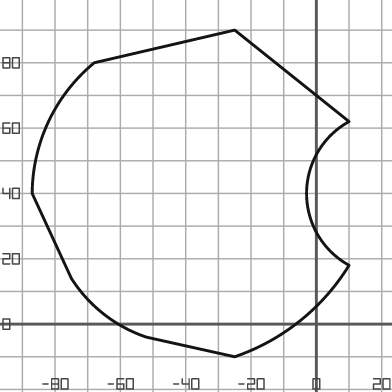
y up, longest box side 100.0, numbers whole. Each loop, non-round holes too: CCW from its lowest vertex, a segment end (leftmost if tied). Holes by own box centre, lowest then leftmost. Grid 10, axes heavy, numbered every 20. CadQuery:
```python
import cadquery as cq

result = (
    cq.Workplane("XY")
    .moveTo(-25.0, -10.0)
    .threePointArc((-5.0, 1.0), (10.0, 18.0))
    .threePointArc((-3.0, 40.0), (10.0, 62.0))
    .lineTo(-25.0, 90.0)
    .lineTo(-68.0, 80.0)
    .threePointArc((-82.0, 62.0), (-87.0, 40.0))
    .lineTo(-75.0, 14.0)
    .threePointArc((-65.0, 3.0), (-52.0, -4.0))
    .close()
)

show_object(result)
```